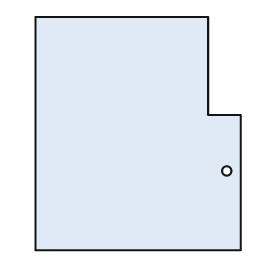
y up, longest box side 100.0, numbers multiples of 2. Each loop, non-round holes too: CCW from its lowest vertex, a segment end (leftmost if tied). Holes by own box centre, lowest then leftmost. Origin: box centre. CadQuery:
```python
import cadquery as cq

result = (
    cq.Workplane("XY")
    .moveTo(-44.0, -50.0)
    .lineTo(44.0, -50.0)
    .lineTo(44.0, 8.0)
    .lineTo(30.0, 8.0)
    .lineTo(30.0, 50.0)
    .lineTo(-44.0, 50.0)
    .close()
    .moveTo(38.0, -16.0)
    .circle(2.0)
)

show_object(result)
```